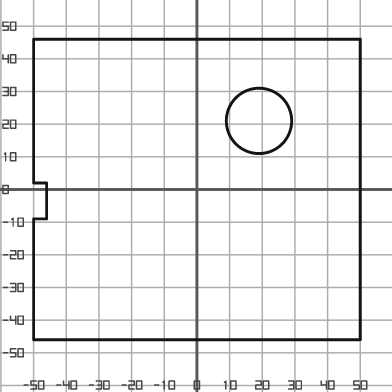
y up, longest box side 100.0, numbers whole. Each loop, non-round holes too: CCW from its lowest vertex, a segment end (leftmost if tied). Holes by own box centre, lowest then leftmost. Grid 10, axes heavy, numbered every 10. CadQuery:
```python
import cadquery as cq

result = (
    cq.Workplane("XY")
    .moveTo(-50.0, -46.0)
    .lineTo(50.0, -46.0)
    .lineTo(50.0, 46.0)
    .lineTo(-50.0, 46.0)
    .lineTo(-50.0, 2.0)
    .lineTo(-46.0, 2.0)
    .lineTo(-46.0, -9.0)
    .lineTo(-50.0, -9.0)
    .close()
    .moveTo(19.0, 21.0)
    .circle(10.0)
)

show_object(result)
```